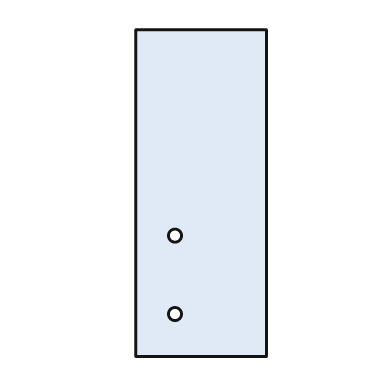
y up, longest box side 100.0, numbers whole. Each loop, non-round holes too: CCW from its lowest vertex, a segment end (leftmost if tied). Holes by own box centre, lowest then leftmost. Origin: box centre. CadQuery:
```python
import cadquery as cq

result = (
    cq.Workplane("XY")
    .moveTo(-20.0, -50.0)
    .lineTo(20.0, -50.0)
    .lineTo(20.0, 50.0)
    .lineTo(-20.0, 50.0)
    .close()
    .moveTo(-8.0, -37.0)
    .circle(2.0)
    .moveTo(-8.0, -13.0)
    .circle(2.0)
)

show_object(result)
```